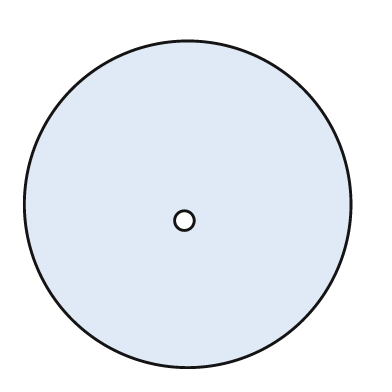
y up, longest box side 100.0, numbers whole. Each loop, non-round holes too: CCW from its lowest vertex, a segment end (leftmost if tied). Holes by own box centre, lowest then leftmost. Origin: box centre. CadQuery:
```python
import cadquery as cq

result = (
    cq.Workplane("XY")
    .moveTo(0.0, 0.0)
    .circle(50.0)
    .moveTo(-1.0, -5.0)
    .circle(3.0)
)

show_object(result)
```